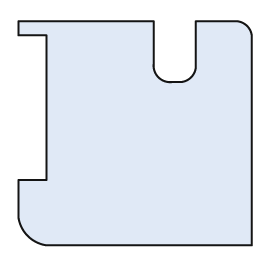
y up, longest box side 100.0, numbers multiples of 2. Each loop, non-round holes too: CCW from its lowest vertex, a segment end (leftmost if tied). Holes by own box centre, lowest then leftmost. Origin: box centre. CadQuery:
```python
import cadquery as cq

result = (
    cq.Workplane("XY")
    .moveTo(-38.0, -48.0)
    .lineTo(50.0, -48.0)
    .lineTo(50.0, 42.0)
    .threePointArc((48.0, 46.0), (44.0, 48.0))
    .lineTo(26.0, 48.0)
    .lineTo(26.0, 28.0)
    .threePointArc((24.0, 24.0), (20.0, 22.0))
    .lineTo(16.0, 22.0)
    .threePointArc((10.0, 24.0), (8.0, 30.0))
    .lineTo(8.0, 48.0)
    .lineTo(-50.0, 48.0)
    .lineTo(-50.0, 42.0)
    .lineTo(-38.0, 42.0)
    .lineTo(-38.0, -20.0)
    .lineTo(-50.0, -20.0)
    .lineTo(-50.0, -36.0)
    .threePointArc((-46.0, -44.0), (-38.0, -48.0))
    .close()
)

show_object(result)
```